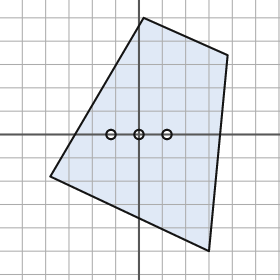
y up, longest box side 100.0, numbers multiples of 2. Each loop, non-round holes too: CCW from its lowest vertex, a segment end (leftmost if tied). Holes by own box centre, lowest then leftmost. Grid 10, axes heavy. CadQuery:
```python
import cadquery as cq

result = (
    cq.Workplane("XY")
    .moveTo(30.0, -50.0)
    .lineTo(38.0, 34.0)
    .lineTo(2.0, 50.0)
    .lineTo(-38.0, -18.0)
    .close()
    .moveTo(-12.0, 0.0)
    .circle(2.0)
    .moveTo(0.0, 0.0)
    .circle(2.0)
    .moveTo(12.0, 0.0)
    .circle(2.0)
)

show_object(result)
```